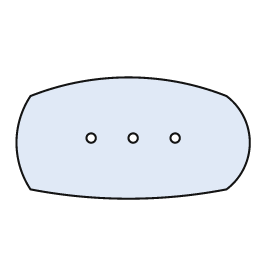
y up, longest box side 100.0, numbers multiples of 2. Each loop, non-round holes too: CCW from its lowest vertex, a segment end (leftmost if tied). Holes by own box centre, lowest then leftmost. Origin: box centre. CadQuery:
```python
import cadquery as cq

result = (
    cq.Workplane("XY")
    .moveTo(-44.0, -22.0)
    .threePointArc((-2.0, -26.0), (40.0, -22.0))
    .threePointArc((50.0, -2.0), (40.0, 18.0))
    .threePointArc((-2.0, 26.0), (-44.0, 18.0))
    .threePointArc((-50.0, -2.0), (-44.0, -22.0))
    .close()
    .moveTo(-18.0, 0.0)
    .circle(2.0)
    .moveTo(0.0, 0.0)
    .circle(2.0)
    .moveTo(18.0, 0.0)
    .circle(2.0)
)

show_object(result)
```